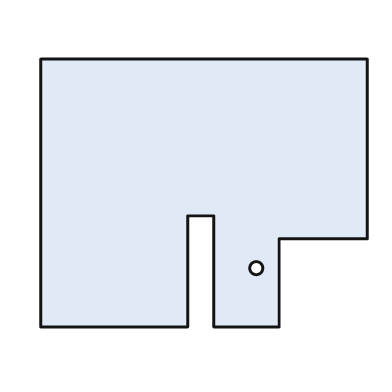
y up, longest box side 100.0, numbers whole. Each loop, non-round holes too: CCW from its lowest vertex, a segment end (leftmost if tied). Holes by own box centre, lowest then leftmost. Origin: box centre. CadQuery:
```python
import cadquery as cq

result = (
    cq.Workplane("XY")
    .moveTo(-50.0, -41.0)
    .lineTo(-5.0, -41.0)
    .lineTo(-5.0, -7.0)
    .lineTo(3.0, -7.0)
    .lineTo(3.0, -41.0)
    .lineTo(23.0, -41.0)
    .lineTo(23.0, -14.0)
    .lineTo(50.0, -14.0)
    .lineTo(50.0, 41.0)
    .lineTo(-50.0, 41.0)
    .close()
    .moveTo(16.0, -23.0)
    .circle(2.0)
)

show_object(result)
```